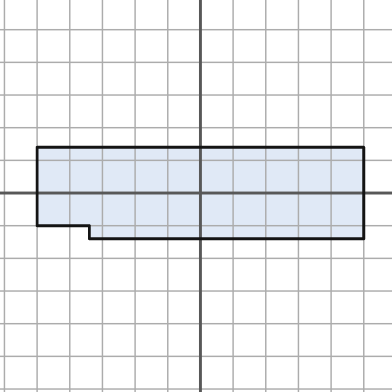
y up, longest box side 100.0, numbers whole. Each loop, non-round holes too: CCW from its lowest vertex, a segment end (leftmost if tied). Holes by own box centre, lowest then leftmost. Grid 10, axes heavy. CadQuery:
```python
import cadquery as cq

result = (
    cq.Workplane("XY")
    .moveTo(-34.0, -14.0)
    .lineTo(50.0, -14.0)
    .lineTo(50.0, 14.0)
    .lineTo(-50.0, 14.0)
    .lineTo(-50.0, -10.0)
    .lineTo(-34.0, -10.0)
    .close()
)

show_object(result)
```